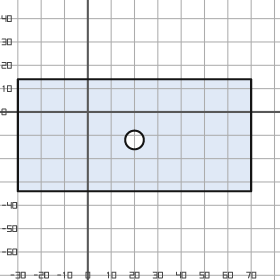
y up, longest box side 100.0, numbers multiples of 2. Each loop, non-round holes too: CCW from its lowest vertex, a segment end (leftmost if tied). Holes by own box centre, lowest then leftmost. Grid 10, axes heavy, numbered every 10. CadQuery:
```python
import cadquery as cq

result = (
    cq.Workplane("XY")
    .moveTo(-30.0, -34.0)
    .lineTo(70.0, -34.0)
    .lineTo(70.0, 14.0)
    .lineTo(-30.0, 14.0)
    .close()
    .moveTo(20.0, -12.0)
    .circle(4.0)
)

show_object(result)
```